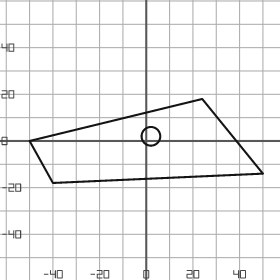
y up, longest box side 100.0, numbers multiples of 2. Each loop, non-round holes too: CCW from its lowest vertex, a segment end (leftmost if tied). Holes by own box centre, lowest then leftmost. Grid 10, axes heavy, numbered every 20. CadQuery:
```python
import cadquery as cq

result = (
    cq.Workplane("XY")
    .moveTo(-40.0, -18.0)
    .lineTo(50.0, -14.0)
    .lineTo(24.0, 18.0)
    .lineTo(-50.0, 0.0)
    .close()
    .moveTo(2.0, 2.0)
    .circle(4.0)
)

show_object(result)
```